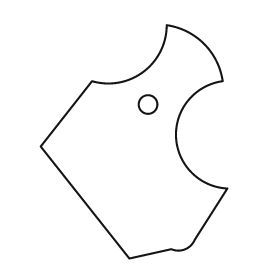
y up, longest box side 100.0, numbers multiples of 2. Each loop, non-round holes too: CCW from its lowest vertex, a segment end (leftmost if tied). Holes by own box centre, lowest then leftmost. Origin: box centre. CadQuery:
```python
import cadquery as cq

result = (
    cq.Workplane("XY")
    .moveTo(-2.0, -50.0)
    .lineTo(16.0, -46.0)
    .threePointArc((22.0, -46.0), (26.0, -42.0))
    .lineTo(40.0, -20.0)
    .threePointArc((18.0, 2.0), (38.0, 26.0))
    .threePointArc((30.0, 42.0), (14.0, 50.0))
    .threePointArc((4.0, 30.0), (-18.0, 26.0))
    .lineTo(-40.0, -2.0)
    .close()
    .moveTo(6.0, 16.0)
    .circle(4.0)
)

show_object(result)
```